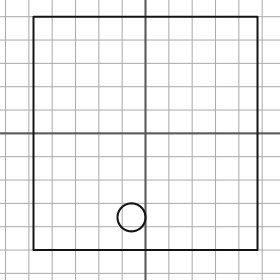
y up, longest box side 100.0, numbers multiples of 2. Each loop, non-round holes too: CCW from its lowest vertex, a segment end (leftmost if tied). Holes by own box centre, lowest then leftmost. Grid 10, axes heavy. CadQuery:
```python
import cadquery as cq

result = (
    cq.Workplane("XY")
    .moveTo(-48.0, -50.0)
    .lineTo(48.0, -50.0)
    .lineTo(48.0, 50.0)
    .lineTo(-48.0, 50.0)
    .close()
    .moveTo(-6.0, -36.0)
    .circle(6.0)
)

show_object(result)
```